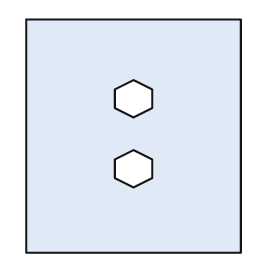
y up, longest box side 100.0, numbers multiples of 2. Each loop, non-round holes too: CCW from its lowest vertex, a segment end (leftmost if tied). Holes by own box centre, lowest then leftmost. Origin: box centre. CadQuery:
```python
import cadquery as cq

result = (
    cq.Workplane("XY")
    .moveTo(-46.0, -50.0)
    .lineTo(46.0, -50.0)
    .lineTo(46.0, 50.0)
    .lineTo(-46.0, 50.0)
    .close()
    .moveTo(0.0, -22.0)
    .lineTo(8.0, -18.0)
    .lineTo(8.0, -10.0)
    .lineTo(0.0, -6.0)
    .lineTo(-8.0, -10.0)
    .lineTo(-8.0, -18.0)
    .close()
    .moveTo(0.0, 8.0)
    .lineTo(8.0, 12.0)
    .lineTo(8.0, 20.0)
    .lineTo(0.0, 24.0)
    .lineTo(-8.0, 20.0)
    .lineTo(-8.0, 12.0)
    .close()
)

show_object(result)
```